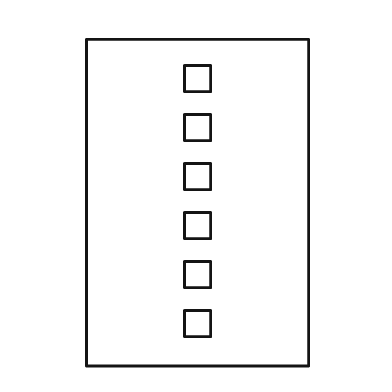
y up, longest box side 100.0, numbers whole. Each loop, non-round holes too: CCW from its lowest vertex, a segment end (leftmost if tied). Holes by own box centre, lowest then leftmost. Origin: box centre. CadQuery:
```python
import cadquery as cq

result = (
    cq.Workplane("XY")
    .moveTo(-34.0, -50.0)
    .lineTo(34.0, -50.0)
    .lineTo(34.0, 50.0)
    .lineTo(-34.0, 50.0)
    .close()
    .moveTo(-4.0, -41.0)
    .lineTo(4.0, -41.0)
    .lineTo(4.0, -33.0)
    .lineTo(-4.0, -33.0)
    .close()
    .moveTo(-4.0, -26.0)
    .lineTo(4.0, -26.0)
    .lineTo(4.0, -18.0)
    .lineTo(-4.0, -18.0)
    .close()
    .moveTo(-4.0, -11.0)
    .lineTo(4.0, -11.0)
    .lineTo(4.0, -3.0)
    .lineTo(-4.0, -3.0)
    .close()
    .moveTo(-4.0, 4.0)
    .lineTo(4.0, 4.0)
    .lineTo(4.0, 12.0)
    .lineTo(-4.0, 12.0)
    .close()
    .moveTo(-4.0, 19.0)
    .lineTo(4.0, 19.0)
    .lineTo(4.0, 27.0)
    .lineTo(-4.0, 27.0)
    .close()
    .moveTo(-4.0, 34.0)
    .lineTo(4.0, 34.0)
    .lineTo(4.0, 42.0)
    .lineTo(-4.0, 42.0)
    .close()
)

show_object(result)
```